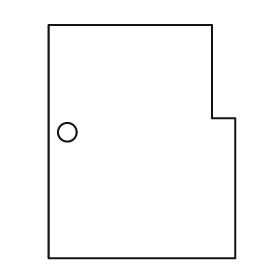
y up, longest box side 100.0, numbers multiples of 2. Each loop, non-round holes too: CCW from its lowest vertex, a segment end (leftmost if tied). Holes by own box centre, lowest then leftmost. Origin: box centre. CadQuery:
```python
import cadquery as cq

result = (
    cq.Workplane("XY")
    .moveTo(-40.0, -50.0)
    .lineTo(40.0, -50.0)
    .lineTo(40.0, 10.0)
    .lineTo(30.0, 10.0)
    .lineTo(30.0, 50.0)
    .lineTo(-40.0, 50.0)
    .close()
    .moveTo(-32.0, 4.0)
    .circle(4.0)
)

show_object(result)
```